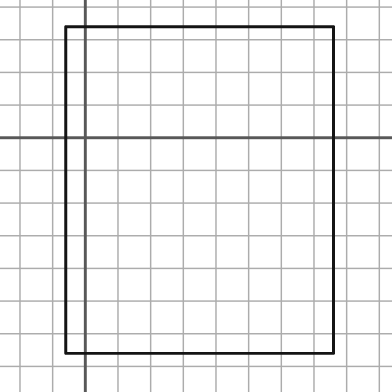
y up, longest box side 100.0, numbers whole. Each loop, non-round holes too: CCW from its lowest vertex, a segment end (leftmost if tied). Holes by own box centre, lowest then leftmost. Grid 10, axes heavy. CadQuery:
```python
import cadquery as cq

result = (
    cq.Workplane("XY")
    .moveTo(-6.0, -66.0)
    .lineTo(76.0, -66.0)
    .lineTo(76.0, 34.0)
    .lineTo(-6.0, 34.0)
    .close()
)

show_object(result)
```